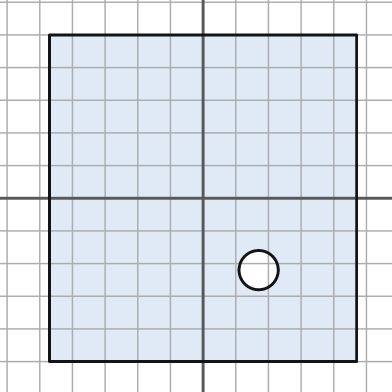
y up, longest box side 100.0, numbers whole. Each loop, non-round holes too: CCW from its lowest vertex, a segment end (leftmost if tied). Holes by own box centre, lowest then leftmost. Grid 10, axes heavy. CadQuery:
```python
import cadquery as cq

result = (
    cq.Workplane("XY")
    .moveTo(-47.0, -50.0)
    .lineTo(47.0, -50.0)
    .lineTo(47.0, 50.0)
    .lineTo(-47.0, 50.0)
    .close()
    .moveTo(17.0, -22.0)
    .circle(6.0)
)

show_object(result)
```